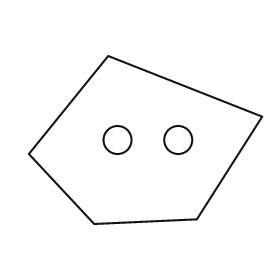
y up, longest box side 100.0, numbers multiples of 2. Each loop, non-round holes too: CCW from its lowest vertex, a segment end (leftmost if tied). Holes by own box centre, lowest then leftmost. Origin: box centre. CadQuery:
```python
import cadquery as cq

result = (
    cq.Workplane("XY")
    .moveTo(-22.0, -36.0)
    .lineTo(22.0, -34.0)
    .lineTo(50.0, 10.0)
    .lineTo(-16.0, 36.0)
    .lineTo(-50.0, -6.0)
    .close()
    .moveTo(-12.0, 0.0)
    .circle(6.0)
    .moveTo(14.0, 0.0)
    .circle(6.0)
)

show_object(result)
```